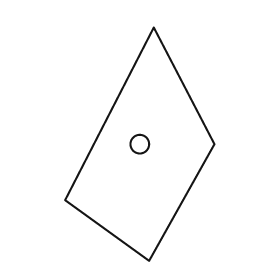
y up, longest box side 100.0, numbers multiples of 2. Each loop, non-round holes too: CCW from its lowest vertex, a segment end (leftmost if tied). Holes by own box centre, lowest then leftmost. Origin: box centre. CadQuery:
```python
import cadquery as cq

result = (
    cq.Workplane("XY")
    .moveTo(4.0, -50.0)
    .lineTo(32.0, 0.0)
    .lineTo(6.0, 50.0)
    .lineTo(-32.0, -24.0)
    .close()
    .moveTo(0.0, 0.0)
    .circle(4.0)
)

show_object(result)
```